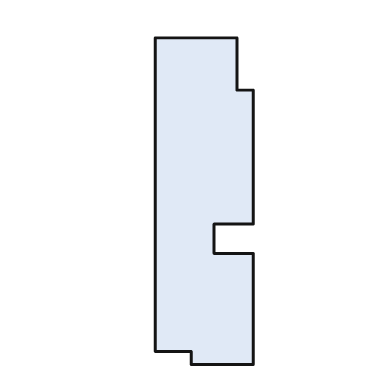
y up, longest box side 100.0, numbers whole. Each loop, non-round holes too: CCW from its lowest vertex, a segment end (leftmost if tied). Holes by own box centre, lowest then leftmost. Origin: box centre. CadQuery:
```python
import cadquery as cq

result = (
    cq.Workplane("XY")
    .moveTo(-4.0, -50.0)
    .lineTo(15.0, -50.0)
    .lineTo(15.0, -16.0)
    .lineTo(3.0, -16.0)
    .lineTo(3.0, -7.0)
    .lineTo(15.0, -7.0)
    .lineTo(15.0, 34.0)
    .lineTo(10.0, 34.0)
    .lineTo(10.0, 50.0)
    .lineTo(-15.0, 50.0)
    .lineTo(-15.0, -46.0)
    .lineTo(-4.0, -46.0)
    .close()
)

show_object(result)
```